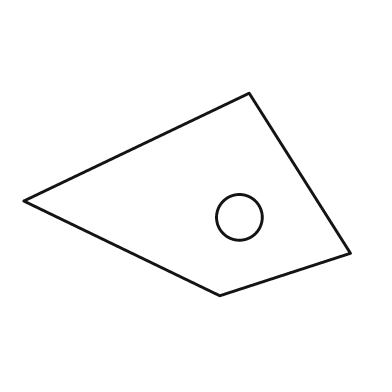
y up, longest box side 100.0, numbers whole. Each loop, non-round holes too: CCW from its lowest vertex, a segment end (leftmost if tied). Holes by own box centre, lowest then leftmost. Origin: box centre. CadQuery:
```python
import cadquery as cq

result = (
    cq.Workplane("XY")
    .moveTo(10.0, -31.0)
    .lineTo(50.0, -18.0)
    .lineTo(19.0, 31.0)
    .lineTo(-50.0, -2.0)
    .close()
    .moveTo(16.0, -7.0)
    .circle(7.0)
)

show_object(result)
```